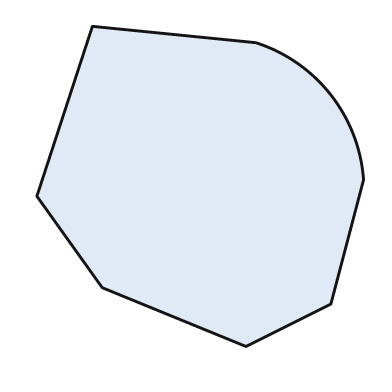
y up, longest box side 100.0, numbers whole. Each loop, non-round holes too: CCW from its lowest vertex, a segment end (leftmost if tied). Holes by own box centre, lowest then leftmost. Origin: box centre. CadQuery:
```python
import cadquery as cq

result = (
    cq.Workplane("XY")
    .moveTo(14.0, -49.0)
    .lineTo(40.0, -36.0)
    .lineTo(50.0, 2.0)
    .threePointArc((40.0, 28.0), (17.0, 44.0))
    .lineTo(-33.0, 49.0)
    .lineTo(-50.0, -3.0)
    .lineTo(-30.0, -31.0)
    .close()
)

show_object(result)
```